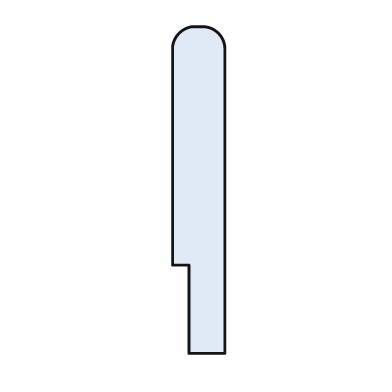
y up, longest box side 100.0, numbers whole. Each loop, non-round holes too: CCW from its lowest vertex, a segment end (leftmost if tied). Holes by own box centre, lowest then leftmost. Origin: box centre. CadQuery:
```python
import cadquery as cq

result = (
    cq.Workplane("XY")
    .moveTo(-3.0, -50.0)
    .lineTo(8.0, -50.0)
    .lineTo(8.0, 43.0)
    .threePointArc((6.0, 48.0), (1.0, 50.0))
    .lineTo(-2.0, 50.0)
    .threePointArc((-6.0, 48.0), (-8.0, 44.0))
    .lineTo(-8.0, -23.0)
    .lineTo(-3.0, -23.0)
    .close()
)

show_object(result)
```